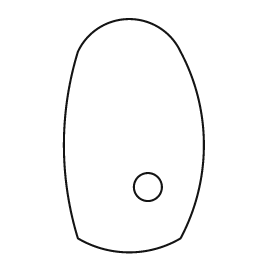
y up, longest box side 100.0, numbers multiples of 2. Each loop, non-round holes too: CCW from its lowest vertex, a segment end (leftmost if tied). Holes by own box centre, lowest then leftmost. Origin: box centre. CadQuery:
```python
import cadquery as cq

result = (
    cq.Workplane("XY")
    .moveTo(-24.0, -44.0)
    .threePointArc((-2.0, -50.0), (20.0, -44.0))
    .threePointArc((30.0, -4.0), (20.0, 36.0))
    .threePointArc((-2.0, 50.0), (-24.0, 36.0))
    .threePointArc((-30.0, -4.0), (-24.0, -44.0))
    .close()
    .moveTo(6.0, -22.0)
    .circle(6.0)
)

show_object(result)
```